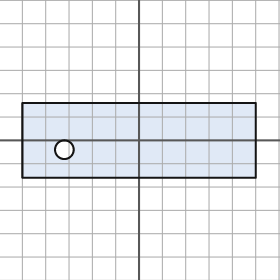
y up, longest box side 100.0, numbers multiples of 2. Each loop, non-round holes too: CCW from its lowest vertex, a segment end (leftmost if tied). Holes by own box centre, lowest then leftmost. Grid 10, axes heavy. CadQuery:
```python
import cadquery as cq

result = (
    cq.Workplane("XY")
    .moveTo(-50.0, -16.0)
    .lineTo(50.0, -16.0)
    .lineTo(50.0, 16.0)
    .lineTo(-50.0, 16.0)
    .close()
    .moveTo(-32.0, -4.0)
    .circle(4.0)
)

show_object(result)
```